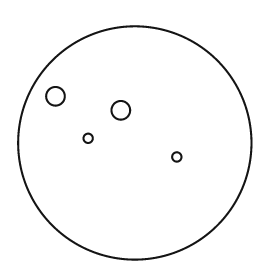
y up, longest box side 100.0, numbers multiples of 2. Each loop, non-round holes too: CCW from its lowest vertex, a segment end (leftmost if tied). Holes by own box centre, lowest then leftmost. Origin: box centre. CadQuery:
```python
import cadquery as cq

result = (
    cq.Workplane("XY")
    .moveTo(0.0, 0.0)
    .circle(50.0)
    .moveTo(18.0, -6.0)
    .circle(2.0)
    .moveTo(-20.0, 2.0)
    .circle(2.0)
    .moveTo(-6.0, 14.0)
    .circle(4.0)
    .moveTo(-34.0, 20.0)
    .circle(4.0)
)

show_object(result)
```